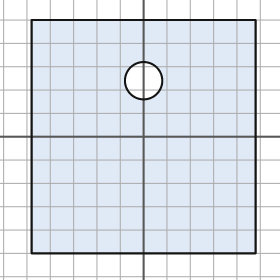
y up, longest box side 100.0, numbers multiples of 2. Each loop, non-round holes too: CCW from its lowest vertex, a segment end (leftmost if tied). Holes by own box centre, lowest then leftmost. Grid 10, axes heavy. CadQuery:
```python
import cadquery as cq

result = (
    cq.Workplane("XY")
    .moveTo(-48.0, -50.0)
    .lineTo(48.0, -50.0)
    .lineTo(48.0, 50.0)
    .lineTo(-48.0, 50.0)
    .close()
    .moveTo(0.0, 24.0)
    .circle(8.0)
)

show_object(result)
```